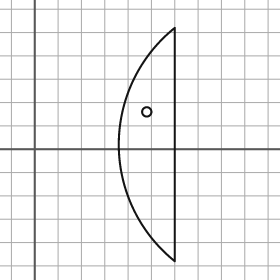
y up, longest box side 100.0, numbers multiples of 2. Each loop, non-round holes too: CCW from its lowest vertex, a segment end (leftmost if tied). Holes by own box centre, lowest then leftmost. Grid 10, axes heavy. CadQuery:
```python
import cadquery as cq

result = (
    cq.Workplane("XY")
    .moveTo(60.0, -48.0)
    .lineTo(60.0, 52.0)
    .threePointArc((36.0, 2.0), (60.0, -48.0))
    .close()
    .moveTo(48.0, 16.0)
    .circle(2.0)
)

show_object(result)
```